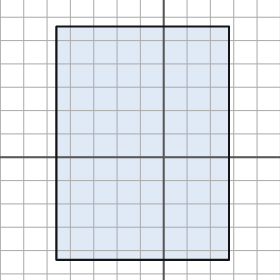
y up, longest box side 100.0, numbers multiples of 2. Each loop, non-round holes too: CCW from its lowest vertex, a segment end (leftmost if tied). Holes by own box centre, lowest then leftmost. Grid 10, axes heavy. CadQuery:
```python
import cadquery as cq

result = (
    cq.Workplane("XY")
    .moveTo(-46.0, -44.0)
    .lineTo(28.0, -44.0)
    .lineTo(28.0, 56.0)
    .lineTo(-46.0, 56.0)
    .close()
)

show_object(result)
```